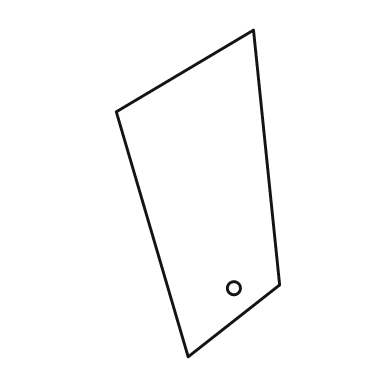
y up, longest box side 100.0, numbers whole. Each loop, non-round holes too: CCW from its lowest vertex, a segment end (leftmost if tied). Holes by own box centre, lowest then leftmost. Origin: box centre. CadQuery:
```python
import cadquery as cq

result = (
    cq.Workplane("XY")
    .moveTo(-3.0, -50.0)
    .lineTo(25.0, -28.0)
    .lineTo(17.0, 50.0)
    .lineTo(-25.0, 25.0)
    .close()
    .moveTo(11.0, -29.0)
    .circle(2.0)
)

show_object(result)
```